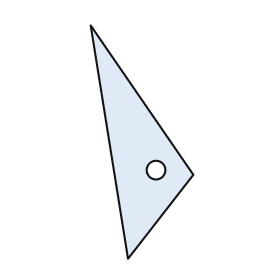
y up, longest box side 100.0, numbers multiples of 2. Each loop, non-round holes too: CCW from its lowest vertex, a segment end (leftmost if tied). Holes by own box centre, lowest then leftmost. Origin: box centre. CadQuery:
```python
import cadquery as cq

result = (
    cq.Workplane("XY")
    .moveTo(-6.0, -50.0)
    .lineTo(22.0, -14.0)
    .lineTo(-22.0, 50.0)
    .close()
    .moveTo(6.0, -12.0)
    .circle(4.0)
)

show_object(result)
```